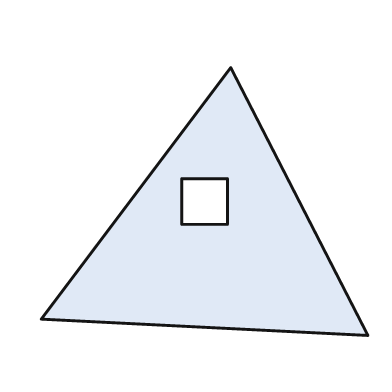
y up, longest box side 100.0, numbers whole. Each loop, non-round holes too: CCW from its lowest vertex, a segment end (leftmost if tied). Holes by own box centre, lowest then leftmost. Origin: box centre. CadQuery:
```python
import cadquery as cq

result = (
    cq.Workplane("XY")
    .moveTo(50.0, -41.0)
    .lineTo(8.0, 41.0)
    .lineTo(-50.0, -36.0)
    .close()
    .moveTo(-7.0, -7.0)
    .lineTo(7.0, -7.0)
    .lineTo(7.0, 7.0)
    .lineTo(-7.0, 7.0)
    .close()
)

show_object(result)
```